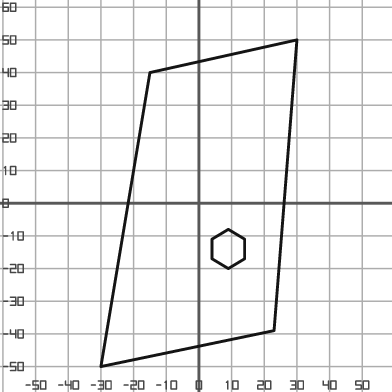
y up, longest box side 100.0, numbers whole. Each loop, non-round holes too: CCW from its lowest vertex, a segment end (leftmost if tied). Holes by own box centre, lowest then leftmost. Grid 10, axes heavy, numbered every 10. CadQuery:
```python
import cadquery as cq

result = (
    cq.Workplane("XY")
    .moveTo(-30.0, -50.0)
    .lineTo(23.0, -39.0)
    .lineTo(30.0, 50.0)
    .lineTo(-15.0, 40.0)
    .close()
    .moveTo(9.0, -20.0)
    .lineTo(14.0, -17.0)
    .lineTo(14.0, -11.0)
    .lineTo(9.0, -8.0)
    .lineTo(4.0, -11.0)
    .lineTo(4.0, -17.0)
    .close()
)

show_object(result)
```